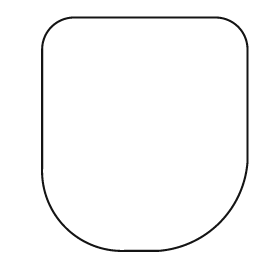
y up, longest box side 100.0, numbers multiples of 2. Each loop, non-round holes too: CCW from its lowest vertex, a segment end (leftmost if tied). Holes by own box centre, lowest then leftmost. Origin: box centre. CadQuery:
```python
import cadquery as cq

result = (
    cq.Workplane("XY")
    .moveTo(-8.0, -50.0)
    .lineTo(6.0, -50.0)
    .threePointArc((32.0, -38.0), (44.0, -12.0))
    .lineTo(44.0, 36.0)
    .threePointArc((40.0, 46.0), (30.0, 50.0))
    .lineTo(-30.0, 50.0)
    .threePointArc((-40.0, 46.0), (-44.0, 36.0))
    .lineTo(-44.0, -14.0)
    .threePointArc((-34.0, -40.0), (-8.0, -50.0))
    .close()
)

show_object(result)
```